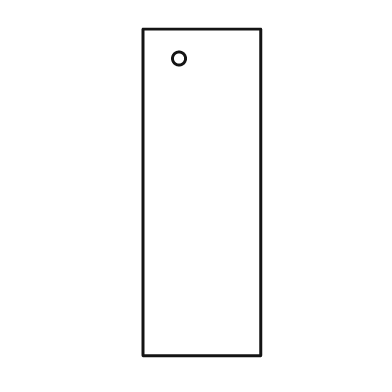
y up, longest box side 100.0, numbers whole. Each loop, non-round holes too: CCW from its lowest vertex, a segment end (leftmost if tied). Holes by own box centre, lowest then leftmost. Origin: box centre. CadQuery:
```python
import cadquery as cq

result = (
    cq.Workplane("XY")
    .moveTo(-18.0, -50.0)
    .lineTo(18.0, -50.0)
    .lineTo(18.0, 50.0)
    .lineTo(-18.0, 50.0)
    .close()
    .moveTo(-7.0, 41.0)
    .circle(2.0)
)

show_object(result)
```